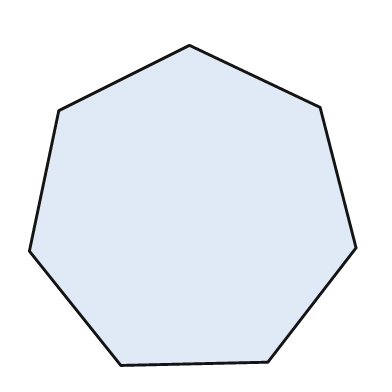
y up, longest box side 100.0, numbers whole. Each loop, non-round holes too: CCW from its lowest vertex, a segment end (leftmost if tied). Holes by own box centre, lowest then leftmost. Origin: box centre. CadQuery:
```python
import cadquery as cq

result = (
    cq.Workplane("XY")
    .moveTo(-22.0, -49.0)
    .lineTo(23.0, -48.0)
    .lineTo(50.0, -13.0)
    .lineTo(39.0, 30.0)
    .lineTo(-1.0, 49.0)
    .lineTo(-41.0, 29.0)
    .lineTo(-50.0, -14.0)
    .close()
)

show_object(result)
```